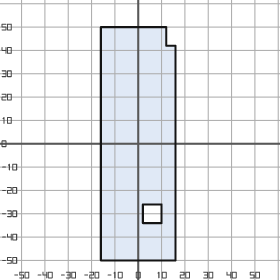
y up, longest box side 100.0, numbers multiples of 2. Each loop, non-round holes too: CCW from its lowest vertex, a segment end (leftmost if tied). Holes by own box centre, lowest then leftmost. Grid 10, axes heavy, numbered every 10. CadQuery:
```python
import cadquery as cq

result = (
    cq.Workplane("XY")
    .moveTo(-16.0, -50.0)
    .lineTo(16.0, -50.0)
    .lineTo(16.0, 42.0)
    .lineTo(12.0, 42.0)
    .lineTo(12.0, 50.0)
    .lineTo(-16.0, 50.0)
    .close()
    .moveTo(2.0, -34.0)
    .lineTo(10.0, -34.0)
    .lineTo(10.0, -26.0)
    .lineTo(2.0, -26.0)
    .close()
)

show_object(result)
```